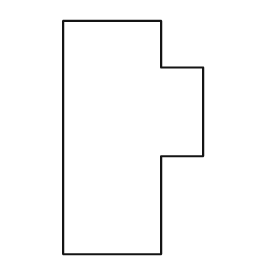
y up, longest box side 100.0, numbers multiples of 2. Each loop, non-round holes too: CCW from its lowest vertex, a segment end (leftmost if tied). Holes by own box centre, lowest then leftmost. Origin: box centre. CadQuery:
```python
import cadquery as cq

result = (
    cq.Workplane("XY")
    .moveTo(-30.0, -50.0)
    .lineTo(12.0, -50.0)
    .lineTo(12.0, -8.0)
    .lineTo(30.0, -8.0)
    .lineTo(30.0, 30.0)
    .lineTo(12.0, 30.0)
    .lineTo(12.0, 50.0)
    .lineTo(-30.0, 50.0)
    .close()
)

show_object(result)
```